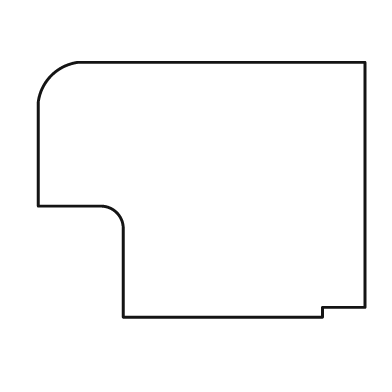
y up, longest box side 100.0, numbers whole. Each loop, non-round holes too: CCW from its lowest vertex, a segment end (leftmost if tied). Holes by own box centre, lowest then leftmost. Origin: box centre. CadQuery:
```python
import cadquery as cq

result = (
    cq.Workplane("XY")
    .moveTo(-24.0, -39.0)
    .lineTo(37.0, -39.0)
    .lineTo(37.0, -36.0)
    .lineTo(50.0, -36.0)
    .lineTo(50.0, 39.0)
    .lineTo(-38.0, 39.0)
    .threePointArc((-46.0, 35.0), (-50.0, 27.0))
    .lineTo(-50.0, -5.0)
    .lineTo(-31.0, -5.0)
    .threePointArc((-26.0, -7.0), (-24.0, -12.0))
    .close()
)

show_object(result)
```